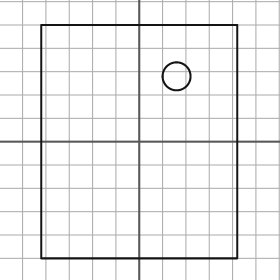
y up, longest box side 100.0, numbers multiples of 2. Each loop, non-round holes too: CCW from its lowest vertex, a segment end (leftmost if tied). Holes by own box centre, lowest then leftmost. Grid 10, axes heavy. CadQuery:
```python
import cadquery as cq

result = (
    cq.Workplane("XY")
    .moveTo(-42.0, -50.0)
    .lineTo(42.0, -50.0)
    .lineTo(42.0, 50.0)
    .lineTo(-42.0, 50.0)
    .close()
    .moveTo(16.0, 28.0)
    .circle(6.0)
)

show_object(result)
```